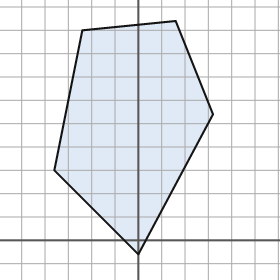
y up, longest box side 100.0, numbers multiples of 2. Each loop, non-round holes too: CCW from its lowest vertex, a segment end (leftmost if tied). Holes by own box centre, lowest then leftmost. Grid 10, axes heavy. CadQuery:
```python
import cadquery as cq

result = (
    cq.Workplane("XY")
    .moveTo(0.0, -6.0)
    .lineTo(32.0, 54.0)
    .lineTo(16.0, 94.0)
    .lineTo(-24.0, 90.0)
    .lineTo(-36.0, 30.0)
    .close()
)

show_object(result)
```